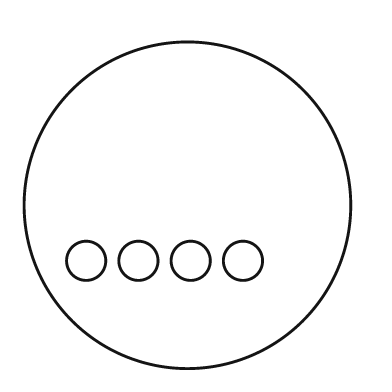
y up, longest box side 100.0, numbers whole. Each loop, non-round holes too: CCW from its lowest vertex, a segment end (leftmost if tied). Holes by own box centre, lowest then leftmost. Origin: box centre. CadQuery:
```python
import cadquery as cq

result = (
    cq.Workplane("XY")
    .moveTo(0.0, 0.0)
    .circle(50.0)
    .moveTo(-31.0, -17.0)
    .circle(6.0)
    .moveTo(-15.0, -17.0)
    .circle(6.0)
    .moveTo(1.0, -17.0)
    .circle(6.0)
    .moveTo(17.0, -17.0)
    .circle(6.0)
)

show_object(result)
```